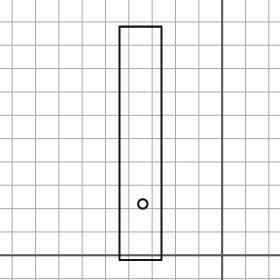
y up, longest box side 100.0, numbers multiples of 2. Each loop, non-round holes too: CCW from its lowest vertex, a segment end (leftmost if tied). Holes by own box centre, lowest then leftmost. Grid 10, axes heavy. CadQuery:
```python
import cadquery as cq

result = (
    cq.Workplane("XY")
    .moveTo(-44.0, -2.0)
    .lineTo(-26.0, -2.0)
    .lineTo(-26.0, 98.0)
    .lineTo(-44.0, 98.0)
    .close()
    .moveTo(-34.0, 22.0)
    .circle(2.0)
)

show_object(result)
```